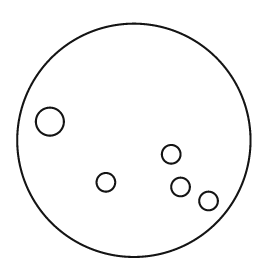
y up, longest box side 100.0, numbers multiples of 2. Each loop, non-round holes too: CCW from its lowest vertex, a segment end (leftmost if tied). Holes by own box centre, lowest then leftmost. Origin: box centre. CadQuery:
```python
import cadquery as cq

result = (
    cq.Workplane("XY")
    .moveTo(0.0, 0.0)
    .circle(50.0)
    .moveTo(32.0, -26.0)
    .circle(4.0)
    .moveTo(20.0, -20.0)
    .circle(4.0)
    .moveTo(-12.0, -18.0)
    .circle(4.0)
    .moveTo(16.0, -6.0)
    .circle(4.0)
    .moveTo(-36.0, 8.0)
    .circle(6.0)
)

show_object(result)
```